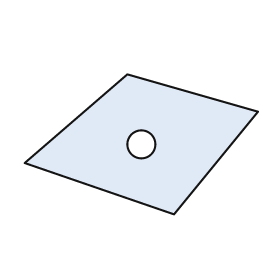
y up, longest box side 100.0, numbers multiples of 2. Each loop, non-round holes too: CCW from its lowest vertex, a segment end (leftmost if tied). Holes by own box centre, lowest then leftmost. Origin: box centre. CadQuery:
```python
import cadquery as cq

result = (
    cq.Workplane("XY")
    .moveTo(14.0, -30.0)
    .lineTo(50.0, 14.0)
    .lineTo(-6.0, 30.0)
    .lineTo(-50.0, -8.0)
    .close()
    .moveTo(0.0, 0.0)
    .circle(6.0)
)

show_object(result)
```